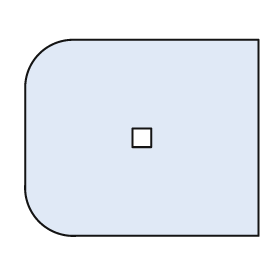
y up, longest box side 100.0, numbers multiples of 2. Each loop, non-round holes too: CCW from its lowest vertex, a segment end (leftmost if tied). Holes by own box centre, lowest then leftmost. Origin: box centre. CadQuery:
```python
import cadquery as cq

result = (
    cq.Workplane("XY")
    .moveTo(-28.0, -42.0)
    .lineTo(50.0, -42.0)
    .lineTo(50.0, 42.0)
    .lineTo(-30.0, 42.0)
    .threePointArc((-44.0, 36.0), (-50.0, 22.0))
    .lineTo(-50.0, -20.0)
    .threePointArc((-44.0, -36.0), (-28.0, -42.0))
    .close()
    .moveTo(-4.0, -4.0)
    .lineTo(4.0, -4.0)
    .lineTo(4.0, 4.0)
    .lineTo(-4.0, 4.0)
    .close()
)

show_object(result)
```